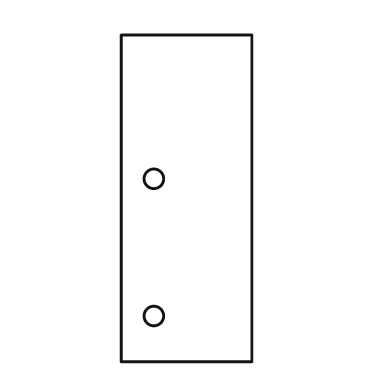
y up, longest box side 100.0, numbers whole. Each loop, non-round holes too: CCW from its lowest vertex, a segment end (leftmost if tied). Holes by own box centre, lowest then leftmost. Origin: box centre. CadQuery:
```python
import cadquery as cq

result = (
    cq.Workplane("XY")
    .moveTo(-20.0, -50.0)
    .lineTo(20.0, -50.0)
    .lineTo(20.0, 50.0)
    .lineTo(-20.0, 50.0)
    .close()
    .moveTo(-10.0, -36.0)
    .circle(3.0)
    .moveTo(-10.0, 6.0)
    .circle(3.0)
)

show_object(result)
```